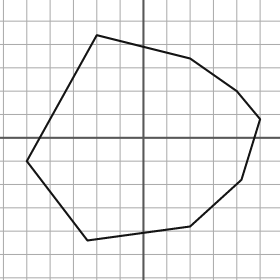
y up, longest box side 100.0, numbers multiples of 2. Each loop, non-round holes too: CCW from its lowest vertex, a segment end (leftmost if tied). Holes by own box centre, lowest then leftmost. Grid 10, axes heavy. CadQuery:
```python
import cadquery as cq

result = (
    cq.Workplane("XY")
    .moveTo(-24.0, -44.0)
    .lineTo(20.0, -38.0)
    .lineTo(42.0, -18.0)
    .lineTo(50.0, 8.0)
    .lineTo(40.0, 20.0)
    .lineTo(20.0, 34.0)
    .lineTo(-20.0, 44.0)
    .lineTo(-50.0, -10.0)
    .close()
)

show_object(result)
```